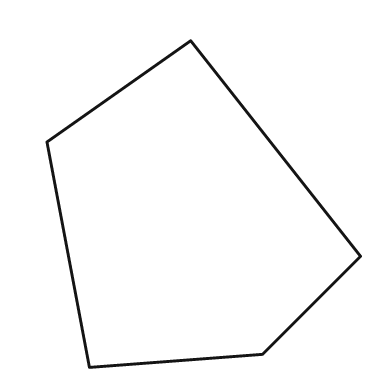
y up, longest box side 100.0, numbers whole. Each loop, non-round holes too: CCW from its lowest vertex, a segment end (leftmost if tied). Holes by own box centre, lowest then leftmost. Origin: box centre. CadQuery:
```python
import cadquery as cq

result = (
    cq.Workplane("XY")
    .moveTo(-35.0, -50.0)
    .lineTo(18.0, -46.0)
    .lineTo(48.0, -16.0)
    .lineTo(-4.0, 50.0)
    .lineTo(-48.0, 19.0)
    .close()
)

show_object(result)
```